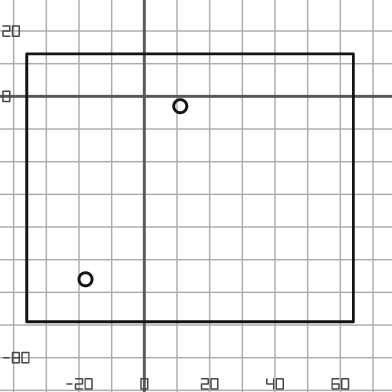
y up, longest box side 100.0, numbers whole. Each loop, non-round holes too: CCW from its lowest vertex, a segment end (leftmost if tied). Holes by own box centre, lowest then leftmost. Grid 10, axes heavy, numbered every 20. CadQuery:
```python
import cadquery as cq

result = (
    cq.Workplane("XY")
    .moveTo(-36.0, -69.0)
    .lineTo(64.0, -69.0)
    .lineTo(64.0, 13.0)
    .lineTo(-36.0, 13.0)
    .close()
    .moveTo(-18.0, -56.0)
    .circle(2.0)
    .moveTo(11.0, -3.0)
    .circle(2.0)
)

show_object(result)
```